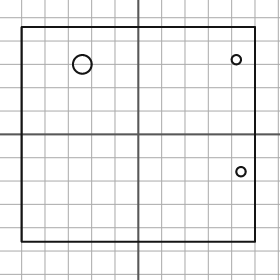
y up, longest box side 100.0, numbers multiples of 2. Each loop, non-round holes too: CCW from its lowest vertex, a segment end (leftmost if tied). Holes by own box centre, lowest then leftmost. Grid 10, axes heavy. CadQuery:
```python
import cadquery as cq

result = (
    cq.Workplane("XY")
    .moveTo(-50.0, -46.0)
    .lineTo(50.0, -46.0)
    .lineTo(50.0, 46.0)
    .lineTo(-50.0, 46.0)
    .close()
    .moveTo(44.0, -16.0)
    .circle(2.0)
    .moveTo(-24.0, 30.0)
    .circle(4.0)
    .moveTo(42.0, 32.0)
    .circle(2.0)
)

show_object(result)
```